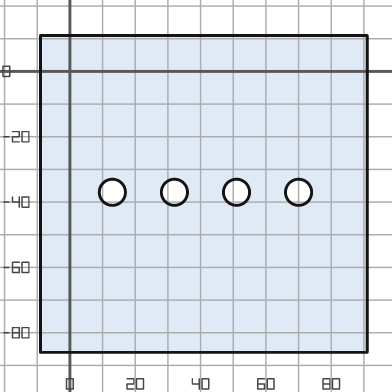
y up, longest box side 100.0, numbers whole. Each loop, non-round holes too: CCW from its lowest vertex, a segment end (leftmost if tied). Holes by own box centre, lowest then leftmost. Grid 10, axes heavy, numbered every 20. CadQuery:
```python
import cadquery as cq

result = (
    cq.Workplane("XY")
    .moveTo(-9.0, -86.0)
    .lineTo(91.0, -86.0)
    .lineTo(91.0, 11.0)
    .lineTo(-9.0, 11.0)
    .close()
    .moveTo(13.0, -37.0)
    .circle(4.0)
    .moveTo(32.0, -37.0)
    .circle(4.0)
    .moveTo(51.0, -37.0)
    .circle(4.0)
    .moveTo(70.0, -37.0)
    .circle(4.0)
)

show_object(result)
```